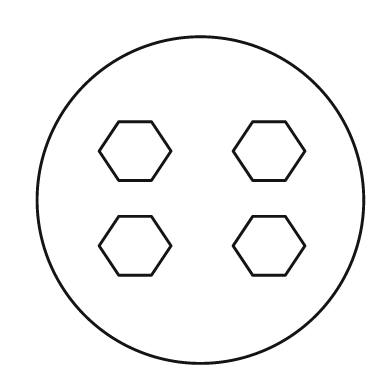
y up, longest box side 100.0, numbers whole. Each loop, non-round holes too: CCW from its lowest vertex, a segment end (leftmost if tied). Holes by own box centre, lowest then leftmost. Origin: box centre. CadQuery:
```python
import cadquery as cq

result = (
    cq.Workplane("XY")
    .moveTo(0.0, 0.0)
    .circle(50.0)
    .moveTo(-25.0, -23.0)
    .lineTo(-15.0, -23.0)
    .lineTo(-9.0, -14.0)
    .lineTo(-15.0, -5.0)
    .lineTo(-25.0, -5.0)
    .lineTo(-31.0, -14.0)
    .close()
    .moveTo(16.0, -23.0)
    .lineTo(26.0, -23.0)
    .lineTo(32.0, -14.0)
    .lineTo(26.0, -5.0)
    .lineTo(16.0, -5.0)
    .lineTo(10.0, -14.0)
    .close()
    .moveTo(-25.0, 6.0)
    .lineTo(-15.0, 6.0)
    .lineTo(-9.0, 15.0)
    .lineTo(-15.0, 24.0)
    .lineTo(-25.0, 24.0)
    .lineTo(-31.0, 15.0)
    .close()
    .moveTo(16.0, 6.0)
    .lineTo(26.0, 6.0)
    .lineTo(32.0, 15.0)
    .lineTo(26.0, 24.0)
    .lineTo(16.0, 24.0)
    .lineTo(10.0, 15.0)
    .close()
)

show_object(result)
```